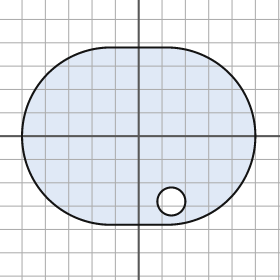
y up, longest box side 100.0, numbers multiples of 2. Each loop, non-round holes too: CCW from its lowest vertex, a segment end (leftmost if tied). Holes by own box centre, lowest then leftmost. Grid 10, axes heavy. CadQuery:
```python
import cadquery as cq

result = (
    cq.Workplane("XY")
    .moveTo(-12.0, -38.0)
    .lineTo(12.0, -38.0)
    .threePointArc((50.0, 0.0), (12.0, 38.0))
    .lineTo(-12.0, 38.0)
    .threePointArc((-50.0, 0.0), (-12.0, -38.0))
    .close()
    .moveTo(14.0, -28.0)
    .circle(6.0)
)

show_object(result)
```